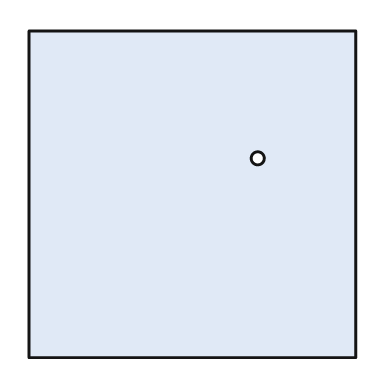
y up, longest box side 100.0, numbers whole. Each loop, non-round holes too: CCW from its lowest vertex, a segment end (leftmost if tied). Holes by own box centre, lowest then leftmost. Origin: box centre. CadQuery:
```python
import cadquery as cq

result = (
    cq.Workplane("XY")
    .moveTo(-50.0, -50.0)
    .lineTo(50.0, -50.0)
    .lineTo(50.0, 50.0)
    .lineTo(-50.0, 50.0)
    .close()
    .moveTo(20.0, 11.0)
    .circle(2.0)
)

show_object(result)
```